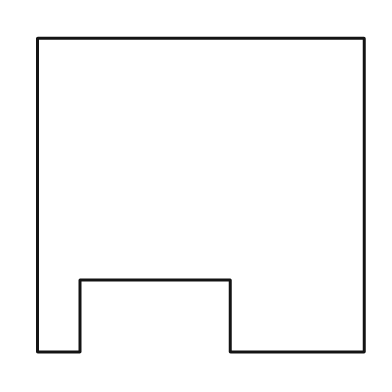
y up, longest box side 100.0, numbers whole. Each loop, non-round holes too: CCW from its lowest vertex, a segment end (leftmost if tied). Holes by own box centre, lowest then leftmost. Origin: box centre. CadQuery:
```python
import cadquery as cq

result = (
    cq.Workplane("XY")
    .moveTo(-50.0, -48.0)
    .lineTo(-37.0, -48.0)
    .lineTo(-37.0, -26.0)
    .lineTo(9.0, -26.0)
    .lineTo(9.0, -48.0)
    .lineTo(50.0, -48.0)
    .lineTo(50.0, 48.0)
    .lineTo(-50.0, 48.0)
    .close()
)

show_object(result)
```